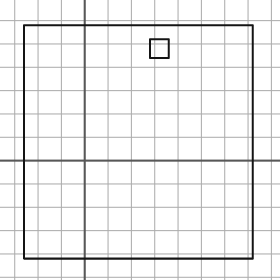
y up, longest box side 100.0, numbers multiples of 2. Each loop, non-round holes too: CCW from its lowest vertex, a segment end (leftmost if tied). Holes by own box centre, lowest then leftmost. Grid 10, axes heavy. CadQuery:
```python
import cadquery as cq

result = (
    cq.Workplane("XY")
    .moveTo(-26.0, -42.0)
    .lineTo(72.0, -42.0)
    .lineTo(72.0, 58.0)
    .lineTo(-26.0, 58.0)
    .close()
    .moveTo(28.0, 44.0)
    .lineTo(36.0, 44.0)
    .lineTo(36.0, 52.0)
    .lineTo(28.0, 52.0)
    .close()
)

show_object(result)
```